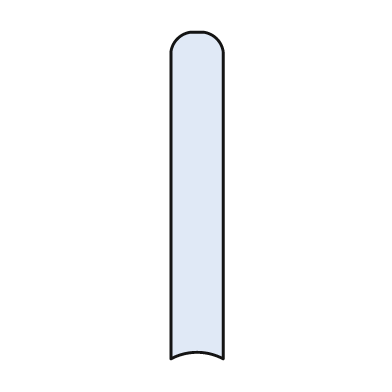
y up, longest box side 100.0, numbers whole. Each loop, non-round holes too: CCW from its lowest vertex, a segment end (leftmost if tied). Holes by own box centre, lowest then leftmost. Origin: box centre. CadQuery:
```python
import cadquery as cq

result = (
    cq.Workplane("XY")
    .moveTo(-8.0, -50.0)
    .threePointArc((0.0, -48.0), (8.0, -50.0))
    .lineTo(8.0, 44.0)
    .threePointArc((6.0, 48.0), (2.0, 50.0))
    .lineTo(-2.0, 50.0)
    .threePointArc((-6.0, 48.0), (-8.0, 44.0))
    .close()
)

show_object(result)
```